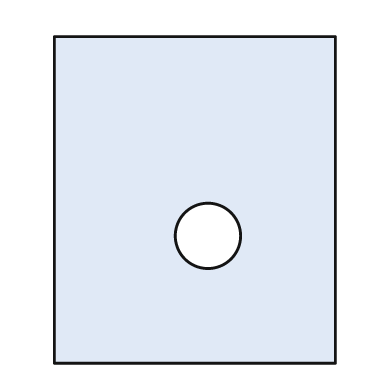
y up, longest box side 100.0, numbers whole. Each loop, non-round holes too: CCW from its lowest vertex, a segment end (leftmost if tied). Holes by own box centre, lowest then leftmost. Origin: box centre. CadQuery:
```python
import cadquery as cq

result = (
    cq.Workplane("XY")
    .moveTo(-43.0, -50.0)
    .lineTo(43.0, -50.0)
    .lineTo(43.0, 50.0)
    .lineTo(-43.0, 50.0)
    .close()
    .moveTo(4.0, -11.0)
    .circle(10.0)
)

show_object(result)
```